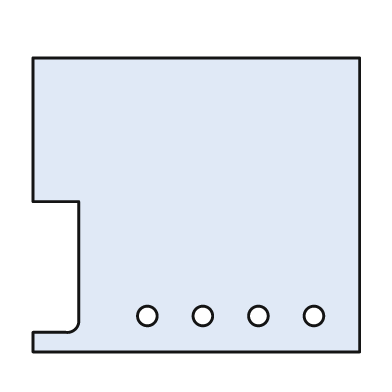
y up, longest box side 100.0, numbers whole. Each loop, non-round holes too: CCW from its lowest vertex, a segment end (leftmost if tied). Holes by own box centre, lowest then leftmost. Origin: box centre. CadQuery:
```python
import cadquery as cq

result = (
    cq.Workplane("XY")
    .moveTo(-50.0, -45.0)
    .lineTo(50.0, -45.0)
    .lineTo(50.0, 45.0)
    .lineTo(-50.0, 45.0)
    .lineTo(-50.0, 1.0)
    .lineTo(-36.0, 1.0)
    .lineTo(-36.0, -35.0)
    .threePointArc((-37.0, -38.0), (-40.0, -39.0))
    .lineTo(-50.0, -39.0)
    .close()
    .moveTo(-15.0, -34.0)
    .circle(3.0)
    .moveTo(2.0, -34.0)
    .circle(3.0)
    .moveTo(19.0, -34.0)
    .circle(3.0)
    .moveTo(36.0, -34.0)
    .circle(3.0)
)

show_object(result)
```